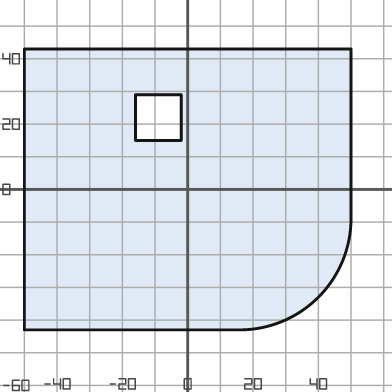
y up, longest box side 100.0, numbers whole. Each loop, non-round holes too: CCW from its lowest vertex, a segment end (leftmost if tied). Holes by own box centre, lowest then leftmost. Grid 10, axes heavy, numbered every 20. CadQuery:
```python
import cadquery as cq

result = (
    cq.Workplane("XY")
    .moveTo(-50.0, -43.0)
    .lineTo(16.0, -43.0)
    .threePointArc((40.0, -33.0), (50.0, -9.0))
    .lineTo(50.0, 43.0)
    .lineTo(-50.0, 43.0)
    .close()
    .moveTo(-16.0, 15.0)
    .lineTo(-2.0, 15.0)
    .lineTo(-2.0, 29.0)
    .lineTo(-16.0, 29.0)
    .close()
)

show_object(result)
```